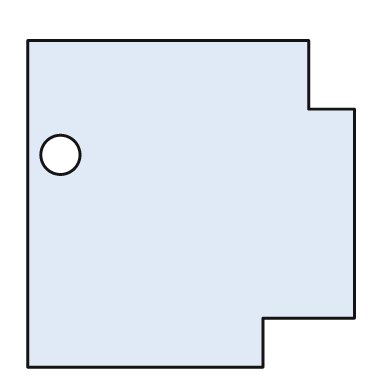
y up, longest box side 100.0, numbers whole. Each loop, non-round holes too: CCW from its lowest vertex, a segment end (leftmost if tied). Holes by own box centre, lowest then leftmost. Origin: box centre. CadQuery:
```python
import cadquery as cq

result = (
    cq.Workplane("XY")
    .moveTo(-50.0, -50.0)
    .lineTo(22.0, -50.0)
    .lineTo(22.0, -35.0)
    .lineTo(50.0, -35.0)
    .lineTo(50.0, 29.0)
    .lineTo(36.0, 29.0)
    .lineTo(36.0, 50.0)
    .lineTo(-50.0, 50.0)
    .close()
    .moveTo(-40.0, 15.0)
    .circle(6.0)
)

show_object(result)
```